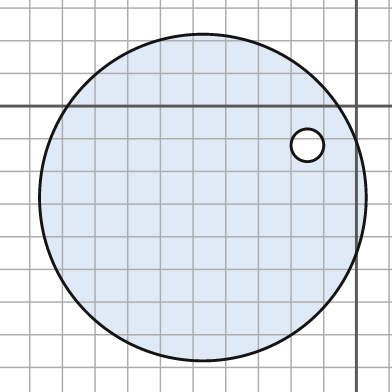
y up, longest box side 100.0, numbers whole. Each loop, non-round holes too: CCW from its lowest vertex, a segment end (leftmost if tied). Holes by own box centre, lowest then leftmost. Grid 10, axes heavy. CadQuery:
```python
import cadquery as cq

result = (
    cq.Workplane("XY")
    .moveTo(-47.0, -28.0)
    .circle(50.0)
    .moveTo(-15.0, -12.0)
    .circle(5.0)
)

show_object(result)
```